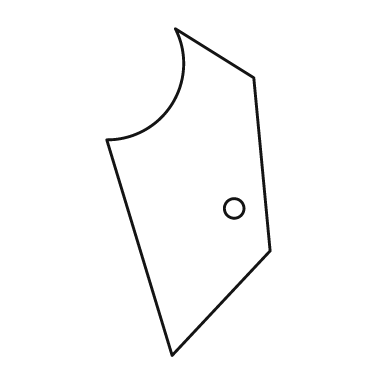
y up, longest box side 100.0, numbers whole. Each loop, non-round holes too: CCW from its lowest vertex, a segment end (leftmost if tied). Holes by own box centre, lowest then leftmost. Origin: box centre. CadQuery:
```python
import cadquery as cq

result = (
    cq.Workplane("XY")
    .moveTo(-5.0, -50.0)
    .lineTo(25.0, -18.0)
    .lineTo(20.0, 35.0)
    .lineTo(-4.0, 50.0)
    .threePointArc((-5.0, 27.0), (-25.0, 16.0))
    .close()
    .moveTo(14.0, -5.0)
    .circle(3.0)
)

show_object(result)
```